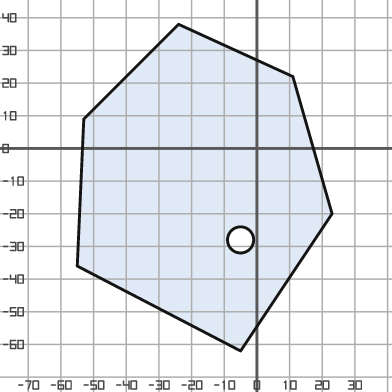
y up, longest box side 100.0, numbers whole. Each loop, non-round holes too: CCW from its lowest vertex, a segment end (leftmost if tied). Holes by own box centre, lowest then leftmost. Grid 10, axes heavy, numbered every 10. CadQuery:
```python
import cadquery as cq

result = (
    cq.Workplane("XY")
    .moveTo(-5.0, -62.0)
    .lineTo(23.0, -20.0)
    .lineTo(11.0, 22.0)
    .lineTo(-24.0, 38.0)
    .lineTo(-53.0, 9.0)
    .lineTo(-55.0, -36.0)
    .close()
    .moveTo(-5.0, -28.0)
    .circle(4.0)
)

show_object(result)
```